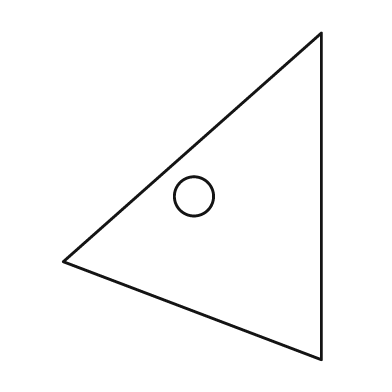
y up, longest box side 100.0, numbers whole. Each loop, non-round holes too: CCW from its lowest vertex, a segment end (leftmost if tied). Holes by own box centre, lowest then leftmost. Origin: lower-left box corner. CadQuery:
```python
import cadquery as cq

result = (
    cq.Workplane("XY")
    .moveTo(79.0, 0.0)
    .lineTo(79.0, 100.0)
    .lineTo(0.0, 30.0)
    .close()
    .moveTo(40.0, 50.0)
    .circle(6.0)
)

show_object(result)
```